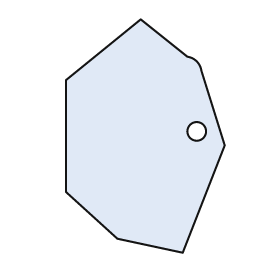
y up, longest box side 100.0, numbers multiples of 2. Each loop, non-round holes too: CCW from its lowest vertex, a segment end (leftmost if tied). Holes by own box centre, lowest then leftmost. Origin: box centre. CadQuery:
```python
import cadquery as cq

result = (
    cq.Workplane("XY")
    .moveTo(16.0, -50.0)
    .lineTo(34.0, -4.0)
    .lineTo(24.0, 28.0)
    .threePointArc((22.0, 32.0), (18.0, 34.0))
    .lineTo(-2.0, 50.0)
    .lineTo(-34.0, 24.0)
    .lineTo(-34.0, -24.0)
    .lineTo(-12.0, -44.0)
    .close()
    .moveTo(22.0, 2.0)
    .circle(4.0)
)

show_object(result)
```